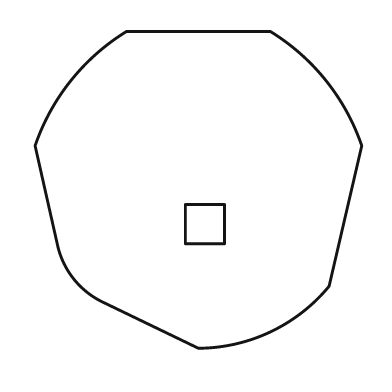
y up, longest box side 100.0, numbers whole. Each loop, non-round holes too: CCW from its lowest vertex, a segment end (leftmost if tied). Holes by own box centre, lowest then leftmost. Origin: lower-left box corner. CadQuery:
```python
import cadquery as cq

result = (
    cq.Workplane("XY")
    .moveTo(50.0, 0.0)
    .threePointArc((72.0, 5.0), (90.0, 19.0))
    .lineTo(100.0, 62.0)
    .threePointArc((89.0, 82.0), (72.0, 97.0))
    .lineTo(28.0, 97.0)
    .threePointArc((11.0, 82.0), (0.0, 62.0))
    .lineTo(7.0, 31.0)
    .threePointArc((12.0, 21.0), (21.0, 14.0))
    .close()
    .moveTo(46.0, 32.0)
    .lineTo(58.0, 32.0)
    .lineTo(58.0, 44.0)
    .lineTo(46.0, 44.0)
    .close()
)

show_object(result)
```